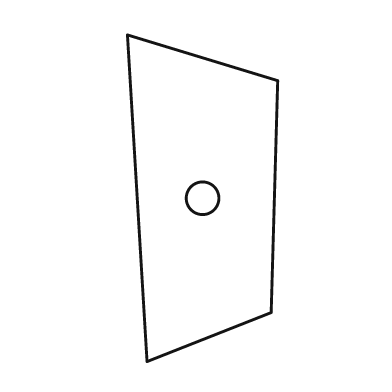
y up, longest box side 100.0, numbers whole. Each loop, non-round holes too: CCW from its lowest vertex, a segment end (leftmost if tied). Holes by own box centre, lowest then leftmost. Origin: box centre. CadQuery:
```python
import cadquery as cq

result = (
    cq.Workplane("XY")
    .moveTo(-17.0, -50.0)
    .lineTo(21.0, -35.0)
    .lineTo(23.0, 36.0)
    .lineTo(-23.0, 50.0)
    .close()
    .moveTo(0.0, 0.0)
    .circle(5.0)
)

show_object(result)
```